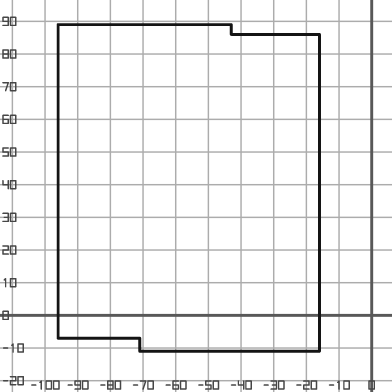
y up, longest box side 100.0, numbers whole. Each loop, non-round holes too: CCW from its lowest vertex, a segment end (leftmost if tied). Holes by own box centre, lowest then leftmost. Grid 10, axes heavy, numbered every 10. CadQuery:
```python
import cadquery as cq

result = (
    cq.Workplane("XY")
    .moveTo(-71.0, -11.0)
    .lineTo(-16.0, -11.0)
    .lineTo(-16.0, 86.0)
    .lineTo(-43.0, 86.0)
    .lineTo(-43.0, 89.0)
    .lineTo(-96.0, 89.0)
    .lineTo(-96.0, -7.0)
    .lineTo(-71.0, -7.0)
    .close()
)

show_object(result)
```